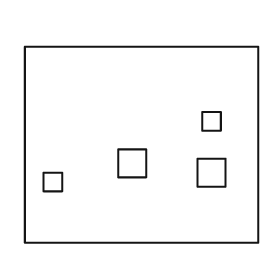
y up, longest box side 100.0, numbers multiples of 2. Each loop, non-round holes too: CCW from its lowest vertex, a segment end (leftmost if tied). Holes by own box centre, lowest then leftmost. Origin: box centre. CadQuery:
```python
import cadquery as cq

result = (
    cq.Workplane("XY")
    .moveTo(-50.0, -42.0)
    .lineTo(50.0, -42.0)
    .lineTo(50.0, 42.0)
    .lineTo(-50.0, 42.0)
    .close()
    .moveTo(-42.0, -20.0)
    .lineTo(-34.0, -20.0)
    .lineTo(-34.0, -12.0)
    .lineTo(-42.0, -12.0)
    .close()
    .moveTo(24.0, -18.0)
    .lineTo(36.0, -18.0)
    .lineTo(36.0, -6.0)
    .lineTo(24.0, -6.0)
    .close()
    .moveTo(-10.0, -14.0)
    .lineTo(2.0, -14.0)
    .lineTo(2.0, -2.0)
    .lineTo(-10.0, -2.0)
    .close()
    .moveTo(26.0, 6.0)
    .lineTo(34.0, 6.0)
    .lineTo(34.0, 14.0)
    .lineTo(26.0, 14.0)
    .close()
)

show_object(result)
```